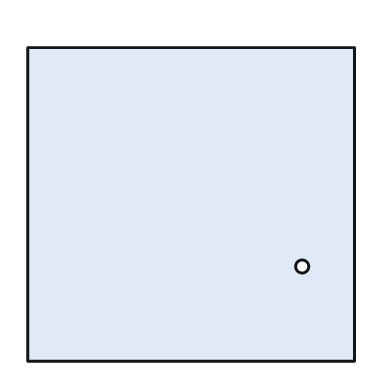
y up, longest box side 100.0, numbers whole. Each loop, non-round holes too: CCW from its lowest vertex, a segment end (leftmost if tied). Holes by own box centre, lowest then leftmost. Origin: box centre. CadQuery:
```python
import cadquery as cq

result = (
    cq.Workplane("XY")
    .moveTo(-50.0, -48.0)
    .lineTo(50.0, -48.0)
    .lineTo(50.0, 48.0)
    .lineTo(-50.0, 48.0)
    .close()
    .moveTo(34.0, -19.0)
    .circle(2.0)
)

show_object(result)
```